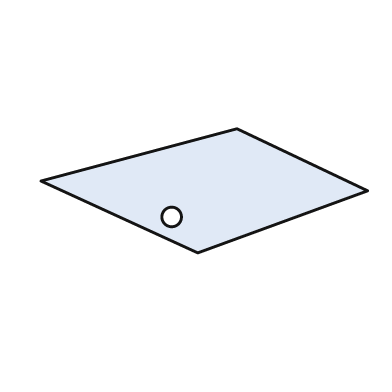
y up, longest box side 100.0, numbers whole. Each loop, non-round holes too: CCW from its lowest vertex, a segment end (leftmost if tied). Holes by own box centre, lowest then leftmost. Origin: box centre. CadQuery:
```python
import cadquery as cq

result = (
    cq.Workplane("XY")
    .moveTo(-2.0, -19.0)
    .lineTo(50.0, 0.0)
    .lineTo(10.0, 19.0)
    .lineTo(-50.0, 3.0)
    .close()
    .moveTo(-10.0, -8.0)
    .circle(3.0)
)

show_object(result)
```